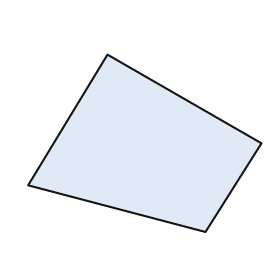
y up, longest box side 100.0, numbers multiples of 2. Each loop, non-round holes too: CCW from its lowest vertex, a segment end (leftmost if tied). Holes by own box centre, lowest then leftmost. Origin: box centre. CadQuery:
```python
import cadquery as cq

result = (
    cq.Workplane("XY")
    .moveTo(26.0, -38.0)
    .lineTo(50.0, 0.0)
    .lineTo(-16.0, 38.0)
    .lineTo(-50.0, -18.0)
    .close()
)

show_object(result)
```